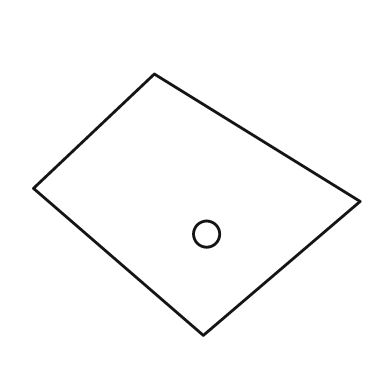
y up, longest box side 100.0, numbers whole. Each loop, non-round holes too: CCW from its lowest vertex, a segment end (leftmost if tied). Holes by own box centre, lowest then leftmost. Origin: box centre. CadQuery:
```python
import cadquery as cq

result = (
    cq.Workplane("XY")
    .moveTo(2.0, -40.0)
    .lineTo(50.0, 1.0)
    .lineTo(-13.0, 40.0)
    .lineTo(-50.0, 5.0)
    .close()
    .moveTo(3.0, -9.0)
    .circle(4.0)
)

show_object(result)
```